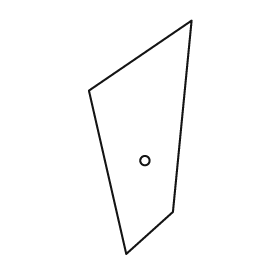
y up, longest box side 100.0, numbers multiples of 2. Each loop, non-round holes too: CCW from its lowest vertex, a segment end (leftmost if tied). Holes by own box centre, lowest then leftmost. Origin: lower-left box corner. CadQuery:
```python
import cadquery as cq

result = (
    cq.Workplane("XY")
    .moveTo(16.0, 0.0)
    .lineTo(36.0, 18.0)
    .lineTo(44.0, 100.0)
    .lineTo(0.0, 70.0)
    .close()
    .moveTo(24.0, 40.0)
    .circle(2.0)
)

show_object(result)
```